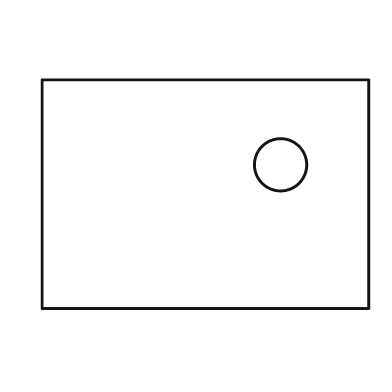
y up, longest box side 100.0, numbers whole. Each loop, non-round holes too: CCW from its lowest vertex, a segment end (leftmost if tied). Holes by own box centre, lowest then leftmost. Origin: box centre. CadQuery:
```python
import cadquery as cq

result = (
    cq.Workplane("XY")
    .moveTo(-50.0, -35.0)
    .lineTo(50.0, -35.0)
    .lineTo(50.0, 35.0)
    .lineTo(-50.0, 35.0)
    .close()
    .moveTo(23.0, 9.0)
    .circle(8.0)
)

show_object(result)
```